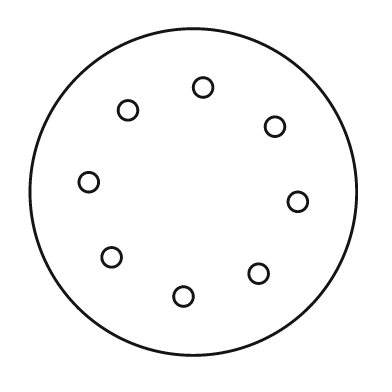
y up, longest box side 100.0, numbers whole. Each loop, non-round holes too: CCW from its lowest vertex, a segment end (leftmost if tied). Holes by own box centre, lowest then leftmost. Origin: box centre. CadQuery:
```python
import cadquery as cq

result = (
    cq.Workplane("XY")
    .moveTo(0.0, 0.0)
    .circle(50.0)
    .moveTo(-3.0, -32.0)
    .circle(3.0)
    .moveTo(20.0, -25.0)
    .circle(3.0)
    .moveTo(-25.0, -20.0)
    .circle(3.0)
    .moveTo(32.0, -3.0)
    .circle(3.0)
    .moveTo(-32.0, 3.0)
    .circle(3.0)
    .moveTo(25.0, 20.0)
    .circle(3.0)
    .moveTo(-20.0, 25.0)
    .circle(3.0)
    .moveTo(3.0, 32.0)
    .circle(3.0)
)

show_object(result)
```